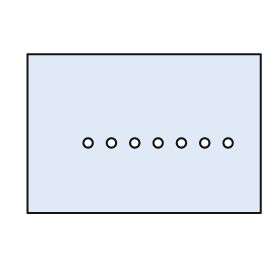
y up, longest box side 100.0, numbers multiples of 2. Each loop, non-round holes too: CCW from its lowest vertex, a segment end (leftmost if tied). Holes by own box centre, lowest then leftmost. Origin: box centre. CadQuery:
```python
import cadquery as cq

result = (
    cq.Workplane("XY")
    .moveTo(-50.0, -34.0)
    .lineTo(50.0, -34.0)
    .lineTo(50.0, 34.0)
    .lineTo(-50.0, 34.0)
    .close()
    .moveTo(-24.0, -4.0)
    .circle(2.0)
    .moveTo(-14.0, -4.0)
    .circle(2.0)
    .moveTo(-4.0, -4.0)
    .circle(2.0)
    .moveTo(6.0, -4.0)
    .circle(2.0)
    .moveTo(16.0, -4.0)
    .circle(2.0)
    .moveTo(26.0, -4.0)
    .circle(2.0)
    .moveTo(36.0, -4.0)
    .circle(2.0)
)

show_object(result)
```